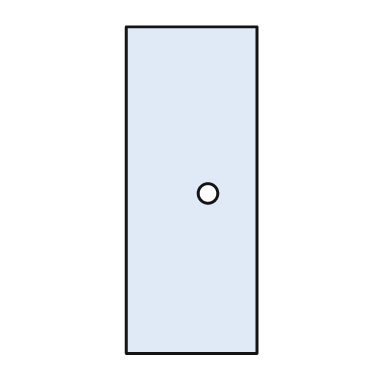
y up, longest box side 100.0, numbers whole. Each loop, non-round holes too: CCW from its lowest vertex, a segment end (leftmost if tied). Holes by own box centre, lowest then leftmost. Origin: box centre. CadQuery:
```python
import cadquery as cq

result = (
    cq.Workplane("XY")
    .moveTo(-20.0, -50.0)
    .lineTo(20.0, -50.0)
    .lineTo(20.0, 50.0)
    .lineTo(-20.0, 50.0)
    .close()
    .moveTo(5.0, -1.0)
    .circle(3.0)
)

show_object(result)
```